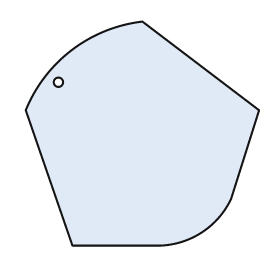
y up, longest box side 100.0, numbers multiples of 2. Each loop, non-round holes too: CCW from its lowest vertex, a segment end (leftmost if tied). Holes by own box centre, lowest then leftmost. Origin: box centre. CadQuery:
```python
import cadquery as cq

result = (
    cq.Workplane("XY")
    .moveTo(-30.0, -48.0)
    .lineTo(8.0, -48.0)
    .threePointArc((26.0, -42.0), (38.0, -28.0))
    .lineTo(50.0, 10.0)
    .lineTo(0.0, 48.0)
    .threePointArc((-30.0, 36.0), (-50.0, 10.0))
    .close()
    .moveTo(-36.0, 22.0)
    .circle(2.0)
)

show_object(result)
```